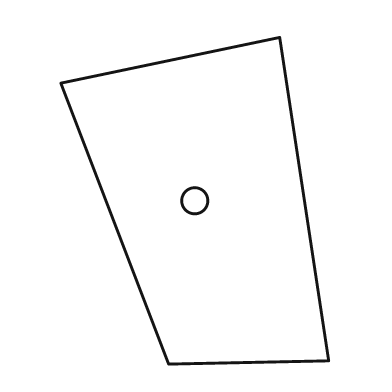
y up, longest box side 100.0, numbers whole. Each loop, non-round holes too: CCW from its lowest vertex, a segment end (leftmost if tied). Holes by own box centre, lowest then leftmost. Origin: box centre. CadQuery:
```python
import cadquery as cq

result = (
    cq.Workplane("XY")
    .moveTo(-8.0, -50.0)
    .lineTo(41.0, -49.0)
    .lineTo(26.0, 50.0)
    .lineTo(-41.0, 36.0)
    .close()
    .moveTo(0.0, 0.0)
    .circle(4.0)
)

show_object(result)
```